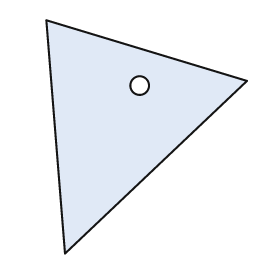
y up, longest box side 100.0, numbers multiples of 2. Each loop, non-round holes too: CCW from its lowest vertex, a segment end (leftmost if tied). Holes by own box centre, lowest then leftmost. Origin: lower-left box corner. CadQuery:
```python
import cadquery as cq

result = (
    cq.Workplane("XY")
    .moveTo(8.0, 0.0)
    .lineTo(86.0, 74.0)
    .lineTo(0.0, 100.0)
    .close()
    .moveTo(40.0, 72.0)
    .circle(4.0)
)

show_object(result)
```